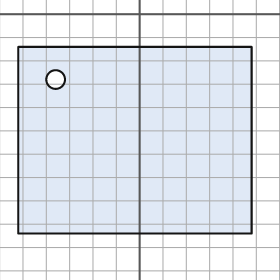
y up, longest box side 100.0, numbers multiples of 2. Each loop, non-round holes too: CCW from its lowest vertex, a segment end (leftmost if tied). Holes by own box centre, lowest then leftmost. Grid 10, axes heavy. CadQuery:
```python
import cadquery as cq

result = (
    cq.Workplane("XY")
    .moveTo(-52.0, -94.0)
    .lineTo(48.0, -94.0)
    .lineTo(48.0, -14.0)
    .lineTo(-52.0, -14.0)
    .close()
    .moveTo(-36.0, -28.0)
    .circle(4.0)
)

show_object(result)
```